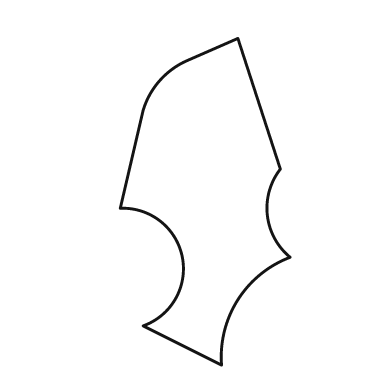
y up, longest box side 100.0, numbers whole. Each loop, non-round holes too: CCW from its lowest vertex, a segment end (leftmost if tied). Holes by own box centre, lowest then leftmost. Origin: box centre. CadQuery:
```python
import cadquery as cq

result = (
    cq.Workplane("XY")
    .moveTo(5.0, -50.0)
    .threePointArc((10.0, -30.0), (26.0, -17.0))
    .threePointArc((19.0, -4.0), (23.0, 10.0))
    .lineTo(10.0, 50.0)
    .lineTo(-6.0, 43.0)
    .threePointArc((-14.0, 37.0), (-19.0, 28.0))
    .lineTo(-26.0, -2.0)
    .threePointArc((-7.0, -17.0), (-19.0, -38.0))
    .close()
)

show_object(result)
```